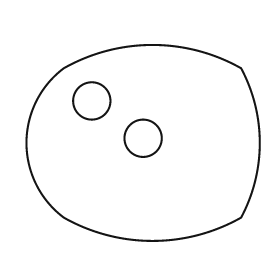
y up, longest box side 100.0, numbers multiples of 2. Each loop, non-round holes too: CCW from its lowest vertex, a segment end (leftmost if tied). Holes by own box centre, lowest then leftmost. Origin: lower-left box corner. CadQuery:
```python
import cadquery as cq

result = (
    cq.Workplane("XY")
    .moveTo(16.0, 10.0)
    .threePointArc((54.0, 0.0), (92.0, 10.0))
    .threePointArc((100.0, 42.0), (92.0, 74.0))
    .threePointArc((54.0, 84.0), (16.0, 74.0))
    .threePointArc((0.0, 42.0), (16.0, 10.0))
    .close()
    .moveTo(50.0, 44.0)
    .circle(8.0)
    .moveTo(28.0, 60.0)
    .circle(8.0)
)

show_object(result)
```